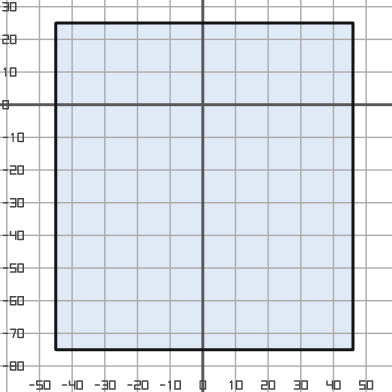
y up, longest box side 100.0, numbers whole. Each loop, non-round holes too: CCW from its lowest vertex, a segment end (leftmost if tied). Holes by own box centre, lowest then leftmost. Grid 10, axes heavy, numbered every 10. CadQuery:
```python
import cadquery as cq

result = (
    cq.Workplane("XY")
    .moveTo(-45.0, -75.0)
    .lineTo(46.0, -75.0)
    .lineTo(46.0, 25.0)
    .lineTo(-45.0, 25.0)
    .close()
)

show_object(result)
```